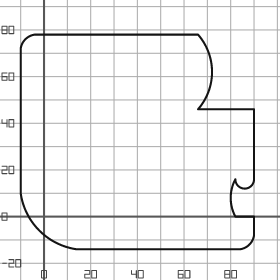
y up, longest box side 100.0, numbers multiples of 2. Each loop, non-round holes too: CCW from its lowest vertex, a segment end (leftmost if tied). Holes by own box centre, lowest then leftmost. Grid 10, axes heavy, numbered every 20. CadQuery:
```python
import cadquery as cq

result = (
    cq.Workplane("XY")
    .moveTo(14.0, -14.0)
    .lineTo(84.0, -14.0)
    .threePointArc((88.0, -12.0), (90.0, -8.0))
    .lineTo(90.0, 0.0)
    .lineTo(82.0, 0.0)
    .threePointArc((80.0, 8.0), (82.0, 16.0))
    .threePointArc((86.0, 12.0), (90.0, 16.0))
    .lineTo(90.0, 46.0)
    .lineTo(66.0, 46.0)
    .threePointArc((72.0, 62.0), (66.0, 78.0))
    .lineTo(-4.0, 78.0)
    .threePointArc((-8.0, 76.0), (-10.0, 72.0))
    .lineTo(-10.0, 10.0)
    .threePointArc((-2.0, -6.0), (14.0, -14.0))
    .close()
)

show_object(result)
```